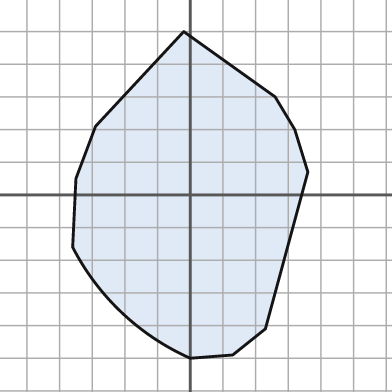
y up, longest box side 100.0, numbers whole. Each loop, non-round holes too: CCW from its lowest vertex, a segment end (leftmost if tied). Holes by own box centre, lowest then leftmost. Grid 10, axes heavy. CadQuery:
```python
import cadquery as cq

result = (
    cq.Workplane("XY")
    .moveTo(0.0, -50.0)
    .lineTo(13.0, -49.0)
    .lineTo(23.0, -41.0)
    .lineTo(36.0, 7.0)
    .lineTo(32.0, 20.0)
    .lineTo(26.0, 30.0)
    .lineTo(-2.0, 50.0)
    .lineTo(-29.0, 21.0)
    .lineTo(-35.0, 5.0)
    .lineTo(-36.0, -16.0)
    .threePointArc((-21.0, -36.0), (0.0, -50.0))
    .close()
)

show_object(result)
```